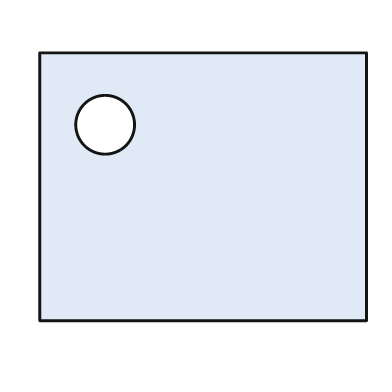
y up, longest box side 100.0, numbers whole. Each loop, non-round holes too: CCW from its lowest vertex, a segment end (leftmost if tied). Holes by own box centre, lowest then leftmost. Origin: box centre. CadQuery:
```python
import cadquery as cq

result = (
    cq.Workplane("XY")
    .moveTo(-50.0, -41.0)
    .lineTo(50.0, -41.0)
    .lineTo(50.0, 41.0)
    .lineTo(-50.0, 41.0)
    .close()
    .moveTo(-30.0, 19.0)
    .circle(9.0)
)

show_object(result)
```